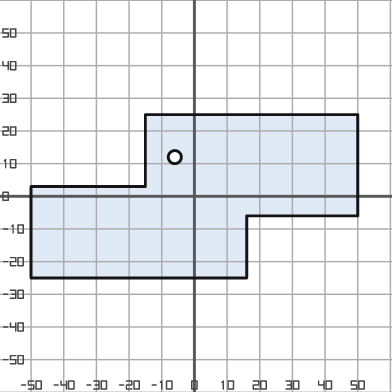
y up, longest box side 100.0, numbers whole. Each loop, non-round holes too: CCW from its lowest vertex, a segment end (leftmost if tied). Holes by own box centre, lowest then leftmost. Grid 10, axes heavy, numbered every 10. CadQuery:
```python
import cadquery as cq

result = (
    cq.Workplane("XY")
    .moveTo(-50.0, -25.0)
    .lineTo(16.0, -25.0)
    .lineTo(16.0, -6.0)
    .lineTo(50.0, -6.0)
    .lineTo(50.0, 25.0)
    .lineTo(-15.0, 25.0)
    .lineTo(-15.0, 3.0)
    .lineTo(-50.0, 3.0)
    .close()
    .moveTo(-6.0, 12.0)
    .circle(2.0)
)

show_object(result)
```